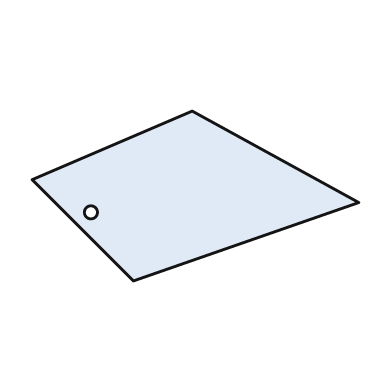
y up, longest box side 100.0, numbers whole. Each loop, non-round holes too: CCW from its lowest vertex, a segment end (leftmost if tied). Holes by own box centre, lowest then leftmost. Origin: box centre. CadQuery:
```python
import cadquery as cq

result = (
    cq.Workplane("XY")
    .moveTo(-19.0, -26.0)
    .lineTo(50.0, -2.0)
    .lineTo(-1.0, 26.0)
    .lineTo(-50.0, 5.0)
    .close()
    .moveTo(-32.0, -5.0)
    .circle(2.0)
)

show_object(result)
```